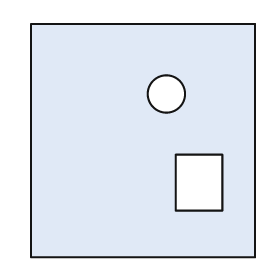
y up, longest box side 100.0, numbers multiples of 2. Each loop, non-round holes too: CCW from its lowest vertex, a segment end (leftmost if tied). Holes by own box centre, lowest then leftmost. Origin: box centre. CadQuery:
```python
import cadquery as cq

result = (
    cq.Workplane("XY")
    .moveTo(-48.0, -50.0)
    .lineTo(48.0, -50.0)
    .lineTo(48.0, 50.0)
    .lineTo(-48.0, 50.0)
    .close()
    .moveTo(14.0, -30.0)
    .lineTo(34.0, -30.0)
    .lineTo(34.0, -6.0)
    .lineTo(14.0, -6.0)
    .close()
    .moveTo(10.0, 20.0)
    .circle(8.0)
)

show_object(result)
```